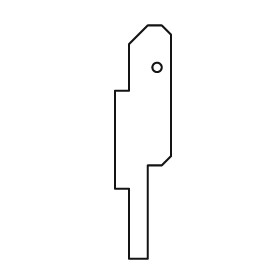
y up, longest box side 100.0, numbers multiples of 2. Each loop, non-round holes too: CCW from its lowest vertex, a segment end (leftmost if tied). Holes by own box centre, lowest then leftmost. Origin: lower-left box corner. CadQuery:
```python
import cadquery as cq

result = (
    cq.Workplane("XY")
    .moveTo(6.0, 0.0)
    .lineTo(14.0, 0.0)
    .lineTo(14.0, 40.0)
    .lineTo(20.0, 40.0)
    .lineTo(24.0, 44.0)
    .lineTo(24.0, 96.0)
    .lineTo(20.0, 100.0)
    .lineTo(14.0, 100.0)
    .lineTo(6.0, 92.0)
    .lineTo(6.0, 72.0)
    .lineTo(0.0, 72.0)
    .lineTo(0.0, 30.0)
    .lineTo(6.0, 30.0)
    .close()
    .moveTo(18.0, 82.0)
    .circle(2.0)
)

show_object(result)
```